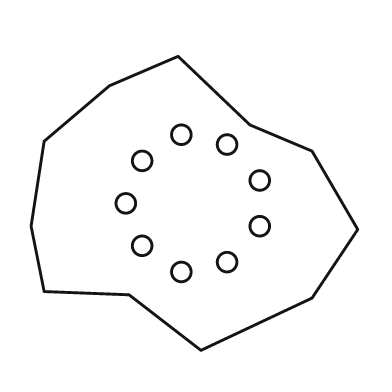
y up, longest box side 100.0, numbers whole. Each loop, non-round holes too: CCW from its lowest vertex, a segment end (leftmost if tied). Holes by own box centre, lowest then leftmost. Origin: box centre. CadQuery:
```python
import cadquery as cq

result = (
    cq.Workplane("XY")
    .moveTo(2.0, -45.0)
    .lineTo(36.0, -29.0)
    .lineTo(50.0, -8.0)
    .lineTo(36.0, 16.0)
    .lineTo(17.0, 24.0)
    .lineTo(-5.0, 45.0)
    .lineTo(-26.0, 36.0)
    .lineTo(-46.0, 19.0)
    .lineTo(-50.0, -7.0)
    .lineTo(-46.0, -27.0)
    .lineTo(-20.0, -28.0)
    .close()
    .moveTo(-4.0, -21.0)
    .circle(3.0)
    .moveTo(10.0, -18.0)
    .circle(3.0)
    .moveTo(-16.0, -13.0)
    .circle(3.0)
    .moveTo(20.0, -7.0)
    .circle(3.0)
    .moveTo(-21.0, 0.0)
    .circle(3.0)
    .moveTo(20.0, 7.0)
    .circle(3.0)
    .moveTo(-16.0, 13.0)
    .circle(3.0)
    .moveTo(10.0, 18.0)
    .circle(3.0)
    .moveTo(-4.0, 21.0)
    .circle(3.0)
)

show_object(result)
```